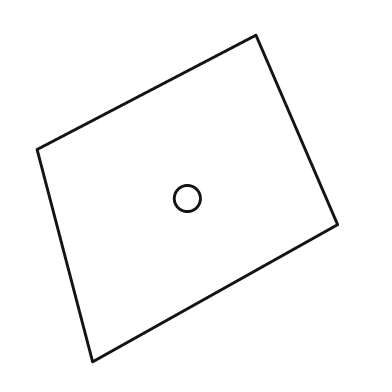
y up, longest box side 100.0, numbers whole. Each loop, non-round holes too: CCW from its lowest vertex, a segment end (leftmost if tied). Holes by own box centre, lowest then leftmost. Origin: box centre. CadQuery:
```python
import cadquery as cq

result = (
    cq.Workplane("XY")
    .moveTo(-29.0, -50.0)
    .lineTo(46.0, -8.0)
    .lineTo(21.0, 50.0)
    .lineTo(-46.0, 15.0)
    .close()
    .moveTo(0.0, 0.0)
    .circle(4.0)
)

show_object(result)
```